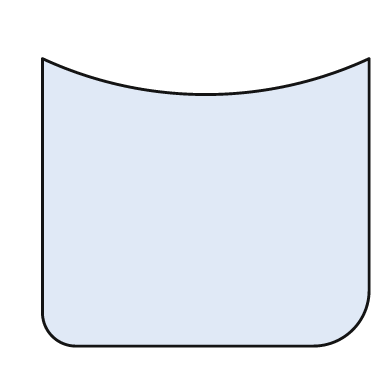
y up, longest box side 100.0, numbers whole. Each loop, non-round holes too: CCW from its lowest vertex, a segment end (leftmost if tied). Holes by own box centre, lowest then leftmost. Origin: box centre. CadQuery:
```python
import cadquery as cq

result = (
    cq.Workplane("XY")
    .moveTo(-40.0, -44.0)
    .lineTo(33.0, -44.0)
    .threePointArc((45.0, -39.0), (50.0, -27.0))
    .lineTo(50.0, 44.0)
    .threePointArc((0.0, 33.0), (-50.0, 44.0))
    .lineTo(-50.0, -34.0)
    .threePointArc((-47.0, -41.0), (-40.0, -44.0))
    .close()
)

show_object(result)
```